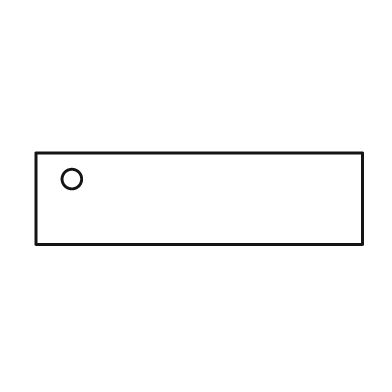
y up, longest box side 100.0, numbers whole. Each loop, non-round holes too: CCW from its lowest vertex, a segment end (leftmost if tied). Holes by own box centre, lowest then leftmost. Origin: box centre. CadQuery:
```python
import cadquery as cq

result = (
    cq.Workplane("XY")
    .moveTo(-50.0, -14.0)
    .lineTo(50.0, -14.0)
    .lineTo(50.0, 14.0)
    .lineTo(-50.0, 14.0)
    .close()
    .moveTo(-39.0, 6.0)
    .circle(3.0)
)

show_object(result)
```